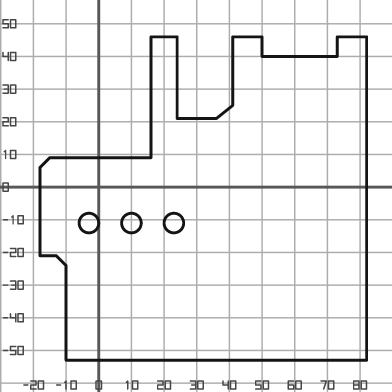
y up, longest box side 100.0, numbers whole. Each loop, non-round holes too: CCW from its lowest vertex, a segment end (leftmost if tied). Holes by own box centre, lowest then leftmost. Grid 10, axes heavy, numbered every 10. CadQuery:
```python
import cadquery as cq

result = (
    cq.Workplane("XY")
    .moveTo(-10.0, -53.0)
    .lineTo(82.0, -53.0)
    .lineTo(82.0, 46.0)
    .lineTo(73.0, 46.0)
    .lineTo(73.0, 40.0)
    .lineTo(50.0, 40.0)
    .lineTo(50.0, 46.0)
    .lineTo(41.0, 46.0)
    .lineTo(41.0, 25.0)
    .lineTo(36.0, 21.0)
    .lineTo(24.0, 21.0)
    .lineTo(24.0, 46.0)
    .lineTo(16.0, 46.0)
    .lineTo(16.0, 9.0)
    .lineTo(-15.0, 9.0)
    .lineTo(-18.0, 6.0)
    .lineTo(-18.0, -21.0)
    .lineTo(-13.0, -21.0)
    .lineTo(-10.0, -24.0)
    .close()
    .moveTo(-3.0, -11.0)
    .circle(3.0)
    .moveTo(10.0, -11.0)
    .circle(3.0)
    .moveTo(23.0, -11.0)
    .circle(3.0)
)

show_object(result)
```